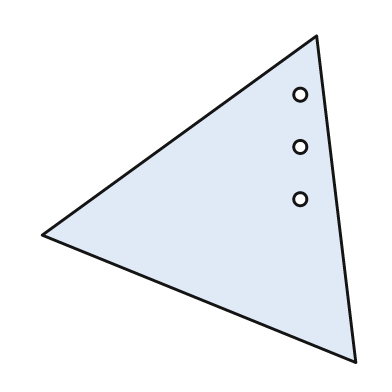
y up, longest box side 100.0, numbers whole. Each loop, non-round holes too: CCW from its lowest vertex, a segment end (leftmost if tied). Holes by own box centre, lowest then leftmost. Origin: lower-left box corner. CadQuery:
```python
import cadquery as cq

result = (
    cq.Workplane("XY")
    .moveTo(96.0, 0.0)
    .lineTo(84.0, 100.0)
    .lineTo(0.0, 39.0)
    .close()
    .moveTo(79.0, 50.0)
    .circle(2.0)
    .moveTo(79.0, 66.0)
    .circle(2.0)
    .moveTo(79.0, 82.0)
    .circle(2.0)
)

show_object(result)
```